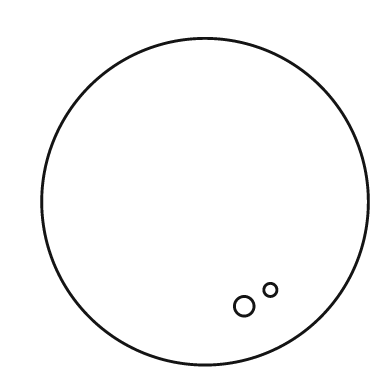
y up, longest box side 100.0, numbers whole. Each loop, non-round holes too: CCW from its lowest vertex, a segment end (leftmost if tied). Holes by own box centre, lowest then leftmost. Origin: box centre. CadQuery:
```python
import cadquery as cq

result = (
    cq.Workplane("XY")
    .moveTo(0.0, 0.0)
    .circle(50.0)
    .moveTo(12.0, -32.0)
    .circle(3.0)
    .moveTo(20.0, -27.0)
    .circle(2.0)
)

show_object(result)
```